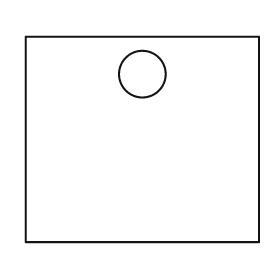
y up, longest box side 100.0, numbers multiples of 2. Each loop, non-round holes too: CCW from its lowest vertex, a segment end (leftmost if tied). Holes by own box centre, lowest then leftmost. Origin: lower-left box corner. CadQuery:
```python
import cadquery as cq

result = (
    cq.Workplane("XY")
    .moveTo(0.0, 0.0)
    .lineTo(100.0, 0.0)
    .lineTo(100.0, 88.0)
    .lineTo(0.0, 88.0)
    .close()
    .moveTo(50.0, 72.0)
    .circle(10.0)
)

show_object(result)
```